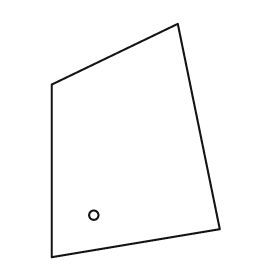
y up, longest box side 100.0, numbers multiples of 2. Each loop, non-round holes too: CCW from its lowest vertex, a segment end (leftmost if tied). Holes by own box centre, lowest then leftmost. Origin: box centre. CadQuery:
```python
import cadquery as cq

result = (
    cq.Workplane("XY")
    .moveTo(-36.0, -50.0)
    .lineTo(36.0, -38.0)
    .lineTo(18.0, 50.0)
    .lineTo(-36.0, 24.0)
    .close()
    .moveTo(-18.0, -32.0)
    .circle(2.0)
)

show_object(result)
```